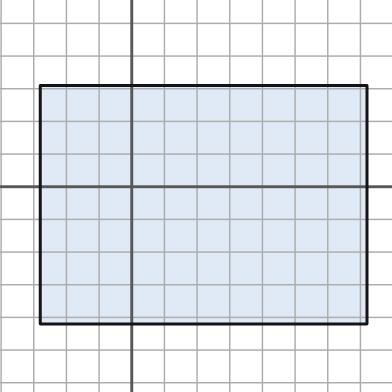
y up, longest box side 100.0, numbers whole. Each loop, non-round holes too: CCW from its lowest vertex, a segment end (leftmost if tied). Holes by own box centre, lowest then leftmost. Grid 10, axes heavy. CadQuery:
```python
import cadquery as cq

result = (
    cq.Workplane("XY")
    .moveTo(-28.0, -42.0)
    .lineTo(72.0, -42.0)
    .lineTo(72.0, 31.0)
    .lineTo(-28.0, 31.0)
    .close()
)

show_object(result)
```